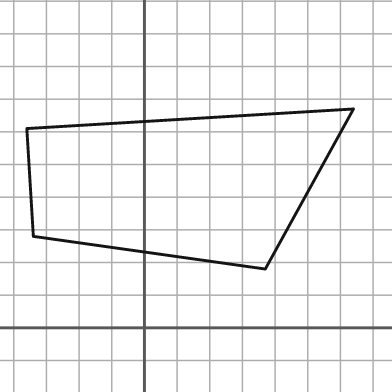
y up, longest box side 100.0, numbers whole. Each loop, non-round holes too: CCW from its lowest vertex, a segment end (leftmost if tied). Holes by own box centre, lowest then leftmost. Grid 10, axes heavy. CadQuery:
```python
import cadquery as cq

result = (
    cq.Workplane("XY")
    .moveTo(37.0, 18.0)
    .lineTo(64.0, 67.0)
    .lineTo(-36.0, 61.0)
    .lineTo(-34.0, 28.0)
    .close()
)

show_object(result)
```